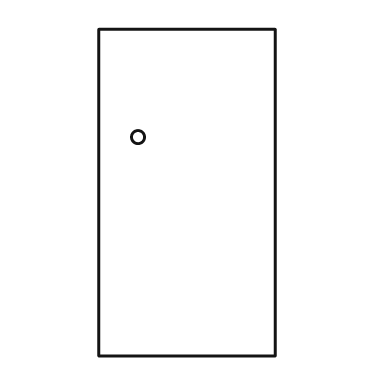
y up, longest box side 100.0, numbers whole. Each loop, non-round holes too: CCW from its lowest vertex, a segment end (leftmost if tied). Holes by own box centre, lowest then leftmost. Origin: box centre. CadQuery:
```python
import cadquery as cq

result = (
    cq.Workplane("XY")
    .moveTo(-27.0, -50.0)
    .lineTo(27.0, -50.0)
    .lineTo(27.0, 50.0)
    .lineTo(-27.0, 50.0)
    .close()
    .moveTo(-15.0, 17.0)
    .circle(2.0)
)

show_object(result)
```